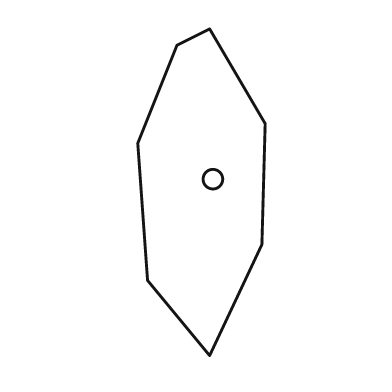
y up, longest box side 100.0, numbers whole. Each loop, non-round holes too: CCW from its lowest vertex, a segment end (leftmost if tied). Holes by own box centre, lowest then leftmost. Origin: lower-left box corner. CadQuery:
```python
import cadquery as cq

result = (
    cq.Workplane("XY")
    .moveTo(22.0, 0.0)
    .lineTo(38.0, 34.0)
    .lineTo(39.0, 71.0)
    .lineTo(22.0, 100.0)
    .lineTo(12.0, 95.0)
    .lineTo(0.0, 65.0)
    .lineTo(3.0, 23.0)
    .close()
    .moveTo(23.0, 54.0)
    .circle(3.0)
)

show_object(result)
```